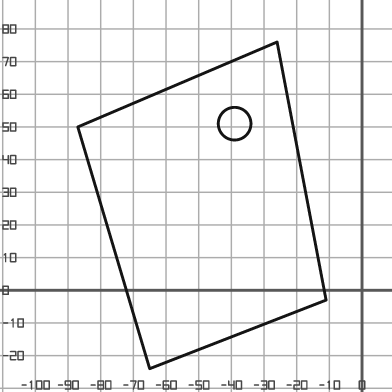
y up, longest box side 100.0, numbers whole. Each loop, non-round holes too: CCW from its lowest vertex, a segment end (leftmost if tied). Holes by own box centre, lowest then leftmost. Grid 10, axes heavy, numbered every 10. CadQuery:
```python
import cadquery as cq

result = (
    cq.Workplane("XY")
    .moveTo(-65.0, -24.0)
    .lineTo(-11.0, -3.0)
    .lineTo(-26.0, 76.0)
    .lineTo(-87.0, 50.0)
    .close()
    .moveTo(-39.0, 51.0)
    .circle(5.0)
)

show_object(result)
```